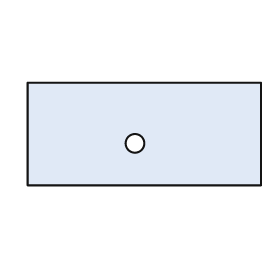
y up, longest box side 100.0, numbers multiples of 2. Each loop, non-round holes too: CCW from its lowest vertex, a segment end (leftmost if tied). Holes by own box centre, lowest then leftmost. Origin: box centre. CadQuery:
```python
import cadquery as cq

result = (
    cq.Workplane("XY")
    .moveTo(-50.0, -22.0)
    .lineTo(50.0, -22.0)
    .lineTo(50.0, 22.0)
    .lineTo(-50.0, 22.0)
    .close()
    .moveTo(-4.0, -4.0)
    .circle(4.0)
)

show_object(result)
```